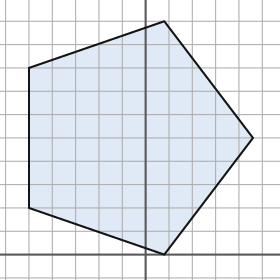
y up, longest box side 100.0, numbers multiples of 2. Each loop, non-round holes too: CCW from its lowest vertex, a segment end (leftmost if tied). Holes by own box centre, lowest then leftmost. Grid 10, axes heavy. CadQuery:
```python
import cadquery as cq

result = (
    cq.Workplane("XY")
    .moveTo(8.0, 0.0)
    .lineTo(46.0, 50.0)
    .lineTo(8.0, 100.0)
    .lineTo(-50.0, 80.0)
    .lineTo(-50.0, 20.0)
    .close()
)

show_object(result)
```